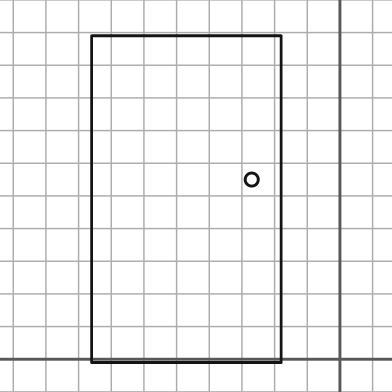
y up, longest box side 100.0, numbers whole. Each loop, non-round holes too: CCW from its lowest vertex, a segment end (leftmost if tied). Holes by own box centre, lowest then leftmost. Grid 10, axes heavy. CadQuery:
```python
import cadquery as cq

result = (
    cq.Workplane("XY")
    .moveTo(-76.0, -1.0)
    .lineTo(-18.0, -1.0)
    .lineTo(-18.0, 99.0)
    .lineTo(-76.0, 99.0)
    .close()
    .moveTo(-27.0, 55.0)
    .circle(2.0)
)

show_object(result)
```